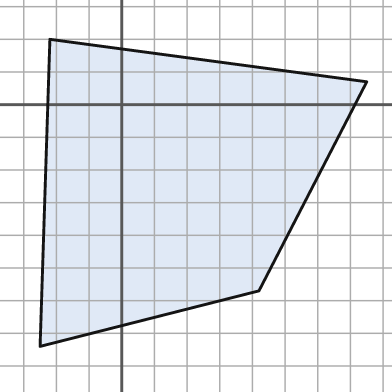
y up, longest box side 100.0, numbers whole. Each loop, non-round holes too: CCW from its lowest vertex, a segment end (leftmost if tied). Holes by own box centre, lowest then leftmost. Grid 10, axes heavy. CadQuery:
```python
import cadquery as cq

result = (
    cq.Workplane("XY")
    .moveTo(-25.0, -74.0)
    .lineTo(42.0, -57.0)
    .lineTo(75.0, 7.0)
    .lineTo(-22.0, 20.0)
    .close()
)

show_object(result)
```